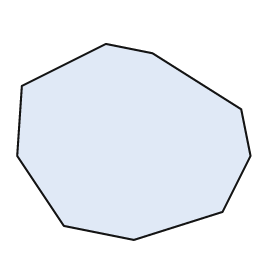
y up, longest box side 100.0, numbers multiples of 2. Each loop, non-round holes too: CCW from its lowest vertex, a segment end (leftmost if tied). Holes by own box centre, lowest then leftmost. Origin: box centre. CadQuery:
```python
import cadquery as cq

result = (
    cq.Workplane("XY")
    .moveTo(0.0, -42.0)
    .lineTo(38.0, -30.0)
    .lineTo(50.0, -6.0)
    .lineTo(46.0, 14.0)
    .lineTo(8.0, 38.0)
    .lineTo(-12.0, 42.0)
    .lineTo(-48.0, 24.0)
    .lineTo(-50.0, -6.0)
    .lineTo(-30.0, -36.0)
    .close()
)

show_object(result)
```